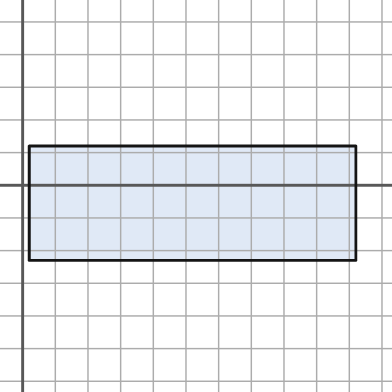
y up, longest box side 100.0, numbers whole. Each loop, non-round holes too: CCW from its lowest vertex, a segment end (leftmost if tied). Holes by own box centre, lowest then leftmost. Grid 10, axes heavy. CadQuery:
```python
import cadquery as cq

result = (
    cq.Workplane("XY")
    .moveTo(2.0, -23.0)
    .lineTo(102.0, -23.0)
    .lineTo(102.0, 12.0)
    .lineTo(2.0, 12.0)
    .close()
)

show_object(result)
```